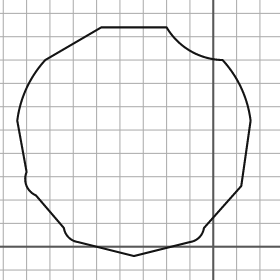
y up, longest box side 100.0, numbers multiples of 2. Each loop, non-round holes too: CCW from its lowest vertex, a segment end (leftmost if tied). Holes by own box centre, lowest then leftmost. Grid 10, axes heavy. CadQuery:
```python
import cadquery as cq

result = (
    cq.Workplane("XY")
    .moveTo(-34.0, -4.0)
    .lineTo(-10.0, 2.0)
    .threePointArc((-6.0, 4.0), (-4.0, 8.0))
    .lineTo(12.0, 26.0)
    .lineTo(16.0, 54.0)
    .threePointArc((12.0, 68.0), (4.0, 80.0))
    .threePointArc((-10.0, 84.0), (-20.0, 94.0))
    .lineTo(-48.0, 94.0)
    .lineTo(-72.0, 80.0)
    .threePointArc((-80.0, 68.0), (-84.0, 54.0))
    .lineTo(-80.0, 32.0)
    .threePointArc((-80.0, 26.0), (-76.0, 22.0))
    .lineTo(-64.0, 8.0)
    .threePointArc((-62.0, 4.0), (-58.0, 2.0))
    .close()
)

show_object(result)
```